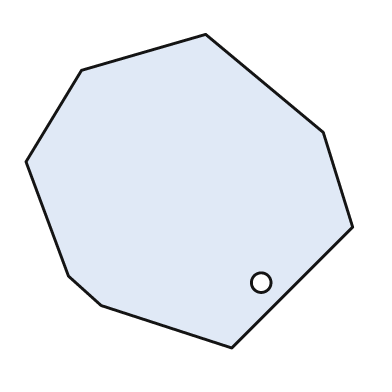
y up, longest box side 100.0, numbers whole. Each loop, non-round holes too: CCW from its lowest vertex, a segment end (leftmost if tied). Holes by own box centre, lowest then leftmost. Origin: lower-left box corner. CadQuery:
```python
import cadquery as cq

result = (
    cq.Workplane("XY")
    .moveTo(63.0, 0.0)
    .lineTo(100.0, 37.0)
    .lineTo(91.0, 66.0)
    .lineTo(55.0, 96.0)
    .lineTo(17.0, 85.0)
    .lineTo(0.0, 57.0)
    .lineTo(13.0, 22.0)
    .lineTo(23.0, 13.0)
    .close()
    .moveTo(72.0, 20.0)
    .circle(3.0)
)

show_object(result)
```